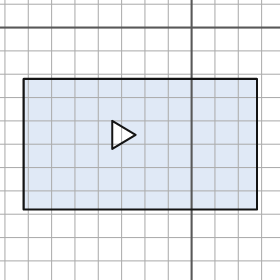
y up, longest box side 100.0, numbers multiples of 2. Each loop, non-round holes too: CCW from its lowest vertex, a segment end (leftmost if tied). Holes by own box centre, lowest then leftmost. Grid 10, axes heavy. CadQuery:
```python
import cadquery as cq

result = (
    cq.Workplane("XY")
    .moveTo(-72.0, -78.0)
    .lineTo(28.0, -78.0)
    .lineTo(28.0, -22.0)
    .lineTo(-72.0, -22.0)
    .close()
    .moveTo(-34.0, -52.0)
    .lineTo(-24.0, -46.0)
    .lineTo(-34.0, -40.0)
    .close()
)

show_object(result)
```